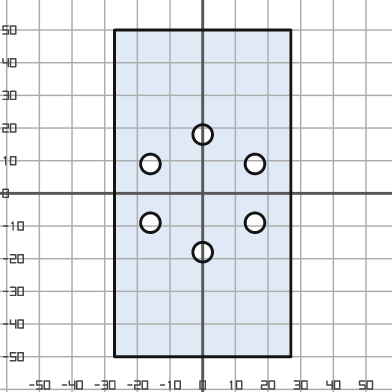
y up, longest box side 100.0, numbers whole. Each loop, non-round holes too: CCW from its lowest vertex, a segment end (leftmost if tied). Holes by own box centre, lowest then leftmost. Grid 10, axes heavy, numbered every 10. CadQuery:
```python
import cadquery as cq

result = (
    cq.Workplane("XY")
    .moveTo(-27.0, -50.0)
    .lineTo(27.0, -50.0)
    .lineTo(27.0, 50.0)
    .lineTo(-27.0, 50.0)
    .close()
    .moveTo(0.0, -18.0)
    .circle(3.0)
    .moveTo(-16.0, -9.0)
    .circle(3.0)
    .moveTo(16.0, -9.0)
    .circle(3.0)
    .moveTo(-16.0, 9.0)
    .circle(3.0)
    .moveTo(16.0, 9.0)
    .circle(3.0)
    .moveTo(0.0, 18.0)
    .circle(3.0)
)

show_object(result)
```